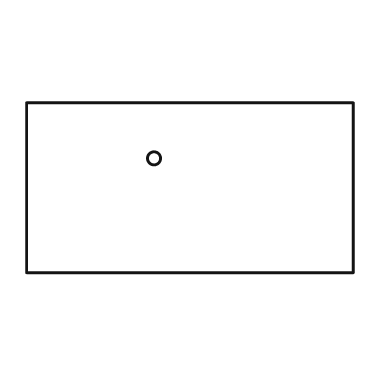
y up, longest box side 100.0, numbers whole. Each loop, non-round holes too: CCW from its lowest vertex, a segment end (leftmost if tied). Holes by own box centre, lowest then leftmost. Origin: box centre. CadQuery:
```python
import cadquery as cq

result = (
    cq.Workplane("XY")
    .moveTo(-50.0, -26.0)
    .lineTo(50.0, -26.0)
    .lineTo(50.0, 26.0)
    .lineTo(-50.0, 26.0)
    .close()
    .moveTo(-11.0, 9.0)
    .circle(2.0)
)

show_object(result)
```